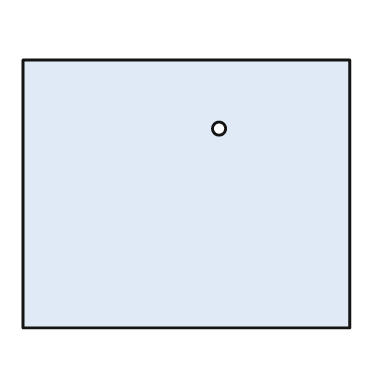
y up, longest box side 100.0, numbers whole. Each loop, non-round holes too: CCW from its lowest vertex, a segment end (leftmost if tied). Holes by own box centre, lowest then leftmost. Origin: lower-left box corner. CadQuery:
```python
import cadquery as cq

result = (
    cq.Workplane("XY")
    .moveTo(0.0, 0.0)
    .lineTo(100.0, 0.0)
    .lineTo(100.0, 82.0)
    .lineTo(0.0, 82.0)
    .close()
    .moveTo(60.0, 61.0)
    .circle(2.0)
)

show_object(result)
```